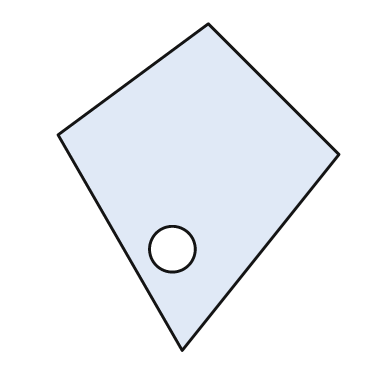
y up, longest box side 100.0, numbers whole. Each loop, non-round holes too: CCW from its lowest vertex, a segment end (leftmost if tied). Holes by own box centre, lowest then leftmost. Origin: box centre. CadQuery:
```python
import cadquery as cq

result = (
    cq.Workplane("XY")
    .moveTo(-5.0, -50.0)
    .lineTo(43.0, 10.0)
    .lineTo(3.0, 50.0)
    .lineTo(-43.0, 16.0)
    .close()
    .moveTo(-8.0, -19.0)
    .circle(7.0)
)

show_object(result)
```